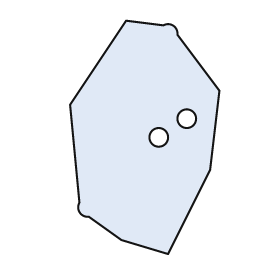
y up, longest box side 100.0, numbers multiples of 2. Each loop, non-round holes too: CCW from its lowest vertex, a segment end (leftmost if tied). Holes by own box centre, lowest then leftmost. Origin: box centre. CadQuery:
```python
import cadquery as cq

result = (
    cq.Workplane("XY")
    .moveTo(10.0, -50.0)
    .lineTo(28.0, -14.0)
    .lineTo(32.0, 20.0)
    .lineTo(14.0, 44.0)
    .threePointArc((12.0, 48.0), (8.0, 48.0))
    .lineTo(-8.0, 50.0)
    .lineTo(-32.0, 14.0)
    .lineTo(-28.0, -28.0)
    .threePointArc((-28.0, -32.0), (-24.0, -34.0))
    .lineTo(-10.0, -44.0)
    .close()
    .moveTo(6.0, 0.0)
    .circle(4.0)
    .moveTo(18.0, 8.0)
    .circle(4.0)
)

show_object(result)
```